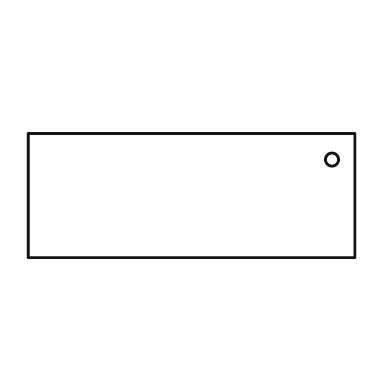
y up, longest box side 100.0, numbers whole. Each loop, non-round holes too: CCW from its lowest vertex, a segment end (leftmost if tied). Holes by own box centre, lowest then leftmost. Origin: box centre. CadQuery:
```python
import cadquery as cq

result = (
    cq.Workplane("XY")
    .moveTo(-50.0, -19.0)
    .lineTo(50.0, -19.0)
    .lineTo(50.0, 19.0)
    .lineTo(-50.0, 19.0)
    .close()
    .moveTo(43.0, 11.0)
    .circle(2.0)
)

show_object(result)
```